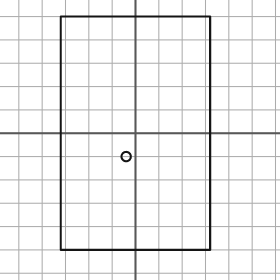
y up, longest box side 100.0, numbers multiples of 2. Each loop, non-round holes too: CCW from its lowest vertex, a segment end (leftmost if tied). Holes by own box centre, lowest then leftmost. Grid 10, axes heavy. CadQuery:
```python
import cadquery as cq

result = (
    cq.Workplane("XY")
    .moveTo(-32.0, -50.0)
    .lineTo(32.0, -50.0)
    .lineTo(32.0, 50.0)
    .lineTo(-32.0, 50.0)
    .close()
    .moveTo(-4.0, -10.0)
    .circle(2.0)
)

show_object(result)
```